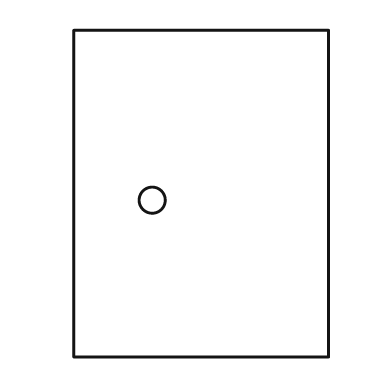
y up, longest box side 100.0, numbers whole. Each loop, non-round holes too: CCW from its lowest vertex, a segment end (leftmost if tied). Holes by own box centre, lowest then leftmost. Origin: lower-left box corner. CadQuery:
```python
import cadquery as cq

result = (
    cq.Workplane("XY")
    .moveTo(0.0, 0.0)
    .lineTo(78.0, 0.0)
    .lineTo(78.0, 100.0)
    .lineTo(0.0, 100.0)
    .close()
    .moveTo(24.0, 48.0)
    .circle(4.0)
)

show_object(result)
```